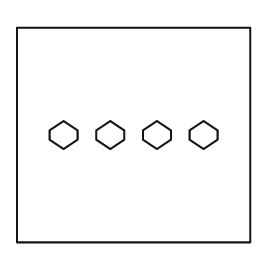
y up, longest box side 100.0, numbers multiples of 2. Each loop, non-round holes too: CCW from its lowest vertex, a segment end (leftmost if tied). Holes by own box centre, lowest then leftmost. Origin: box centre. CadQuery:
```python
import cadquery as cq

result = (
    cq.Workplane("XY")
    .moveTo(-50.0, -46.0)
    .lineTo(50.0, -46.0)
    .lineTo(50.0, 46.0)
    .lineTo(-50.0, 46.0)
    .close()
    .moveTo(-30.0, -6.0)
    .lineTo(-24.0, -2.0)
    .lineTo(-24.0, 2.0)
    .lineTo(-30.0, 6.0)
    .lineTo(-36.0, 2.0)
    .lineTo(-36.0, -2.0)
    .close()
    .moveTo(-10.0, -6.0)
    .lineTo(-4.0, -2.0)
    .lineTo(-4.0, 2.0)
    .lineTo(-10.0, 6.0)
    .lineTo(-16.0, 2.0)
    .lineTo(-16.0, -2.0)
    .close()
    .moveTo(10.0, -6.0)
    .lineTo(16.0, -2.0)
    .lineTo(16.0, 2.0)
    .lineTo(10.0, 6.0)
    .lineTo(4.0, 2.0)
    .lineTo(4.0, -2.0)
    .close()
    .moveTo(30.0, -6.0)
    .lineTo(36.0, -2.0)
    .lineTo(36.0, 2.0)
    .lineTo(30.0, 6.0)
    .lineTo(24.0, 2.0)
    .lineTo(24.0, -2.0)
    .close()
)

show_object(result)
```